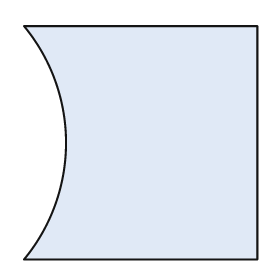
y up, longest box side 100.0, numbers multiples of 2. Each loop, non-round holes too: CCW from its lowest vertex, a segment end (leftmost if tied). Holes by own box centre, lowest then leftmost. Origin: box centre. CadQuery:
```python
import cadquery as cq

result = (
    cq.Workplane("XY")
    .moveTo(-50.0, -50.0)
    .lineTo(50.0, -50.0)
    .lineTo(50.0, 50.0)
    .lineTo(-50.0, 50.0)
    .threePointArc((-32.0, 0.0), (-50.0, -50.0))
    .close()
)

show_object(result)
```